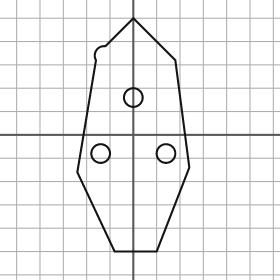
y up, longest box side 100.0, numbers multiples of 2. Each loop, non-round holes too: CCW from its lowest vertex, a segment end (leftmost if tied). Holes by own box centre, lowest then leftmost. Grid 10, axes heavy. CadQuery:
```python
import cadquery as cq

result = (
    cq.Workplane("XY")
    .moveTo(-8.0, -50.0)
    .lineTo(10.0, -50.0)
    .lineTo(24.0, -14.0)
    .lineTo(18.0, 32.0)
    .lineTo(0.0, 50.0)
    .lineTo(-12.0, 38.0)
    .threePointArc((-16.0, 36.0), (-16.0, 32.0))
    .lineTo(-24.0, -16.0)
    .close()
    .moveTo(-14.0, -8.0)
    .circle(4.0)
    .moveTo(14.0, -8.0)
    .circle(4.0)
    .moveTo(0.0, 16.0)
    .circle(4.0)
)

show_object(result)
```